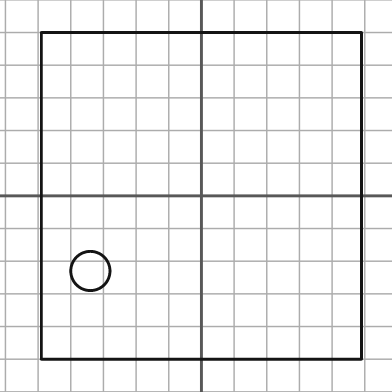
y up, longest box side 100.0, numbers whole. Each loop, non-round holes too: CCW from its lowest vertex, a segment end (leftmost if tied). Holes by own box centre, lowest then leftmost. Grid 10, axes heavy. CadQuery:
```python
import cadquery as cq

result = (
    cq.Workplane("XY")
    .moveTo(-49.0, -50.0)
    .lineTo(49.0, -50.0)
    .lineTo(49.0, 50.0)
    .lineTo(-49.0, 50.0)
    .close()
    .moveTo(-34.0, -23.0)
    .circle(6.0)
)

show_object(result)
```